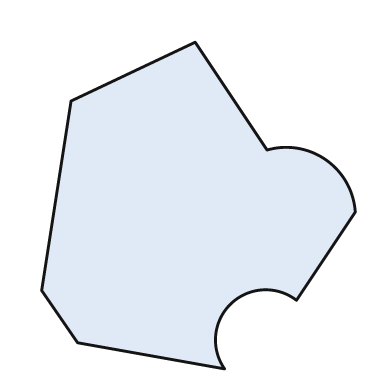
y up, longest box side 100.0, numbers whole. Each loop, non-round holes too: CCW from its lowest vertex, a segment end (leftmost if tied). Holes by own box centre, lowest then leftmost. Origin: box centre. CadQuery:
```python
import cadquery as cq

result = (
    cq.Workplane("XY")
    .moveTo(8.0, -50.0)
    .threePointArc((10.0, -30.0), (30.0, -29.0))
    .lineTo(48.0, -2.0)
    .threePointArc((39.0, 14.0), (21.0, 17.0))
    .lineTo(-1.0, 50.0)
    .lineTo(-39.0, 32.0)
    .lineTo(-48.0, -26.0)
    .lineTo(-37.0, -42.0)
    .close()
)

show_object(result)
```